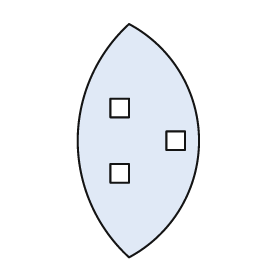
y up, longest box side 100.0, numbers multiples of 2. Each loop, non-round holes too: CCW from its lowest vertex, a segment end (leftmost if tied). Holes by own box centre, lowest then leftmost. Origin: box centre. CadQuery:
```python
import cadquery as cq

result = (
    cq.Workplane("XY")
    .moveTo(-4.0, -50.0)
    .threePointArc((26.0, 0.0), (-4.0, 50.0))
    .threePointArc((-26.0, 0.0), (-4.0, -50.0))
    .close()
    .moveTo(-12.0, -18.0)
    .lineTo(-4.0, -18.0)
    .lineTo(-4.0, -10.0)
    .lineTo(-12.0, -10.0)
    .close()
    .moveTo(12.0, -4.0)
    .lineTo(20.0, -4.0)
    .lineTo(20.0, 4.0)
    .lineTo(12.0, 4.0)
    .close()
    .moveTo(-12.0, 10.0)
    .lineTo(-4.0, 10.0)
    .lineTo(-4.0, 18.0)
    .lineTo(-12.0, 18.0)
    .close()
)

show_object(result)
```